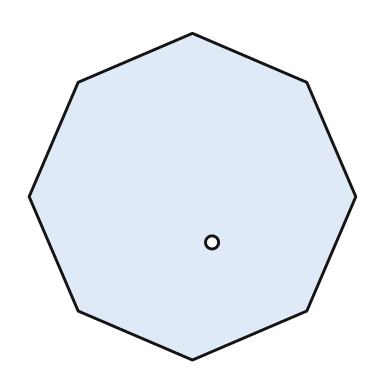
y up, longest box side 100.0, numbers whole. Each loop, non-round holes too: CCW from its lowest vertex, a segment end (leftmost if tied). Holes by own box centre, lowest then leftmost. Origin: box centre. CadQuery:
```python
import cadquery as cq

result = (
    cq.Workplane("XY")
    .moveTo(0.0, -50.0)
    .lineTo(35.0, -35.0)
    .lineTo(50.0, 0.0)
    .lineTo(35.0, 35.0)
    .lineTo(0.0, 50.0)
    .lineTo(-35.0, 35.0)
    .lineTo(-50.0, 0.0)
    .lineTo(-35.0, -35.0)
    .close()
    .moveTo(6.0, -14.0)
    .circle(2.0)
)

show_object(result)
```